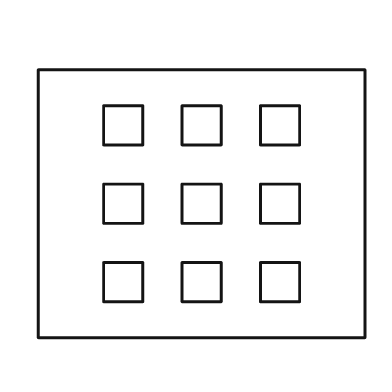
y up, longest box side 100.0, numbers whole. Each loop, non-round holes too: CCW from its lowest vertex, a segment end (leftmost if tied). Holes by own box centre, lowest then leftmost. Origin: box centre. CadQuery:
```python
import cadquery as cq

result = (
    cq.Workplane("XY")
    .moveTo(-50.0, -41.0)
    .lineTo(50.0, -41.0)
    .lineTo(50.0, 41.0)
    .lineTo(-50.0, 41.0)
    .close()
    .moveTo(-30.0, -30.0)
    .lineTo(-18.0, -30.0)
    .lineTo(-18.0, -18.0)
    .lineTo(-30.0, -18.0)
    .close()
    .moveTo(-6.0, -30.0)
    .lineTo(6.0, -30.0)
    .lineTo(6.0, -18.0)
    .lineTo(-6.0, -18.0)
    .close()
    .moveTo(18.0, -30.0)
    .lineTo(30.0, -30.0)
    .lineTo(30.0, -18.0)
    .lineTo(18.0, -18.0)
    .close()
    .moveTo(-30.0, -6.0)
    .lineTo(-18.0, -6.0)
    .lineTo(-18.0, 6.0)
    .lineTo(-30.0, 6.0)
    .close()
    .moveTo(-6.0, -6.0)
    .lineTo(6.0, -6.0)
    .lineTo(6.0, 6.0)
    .lineTo(-6.0, 6.0)
    .close()
    .moveTo(18.0, -6.0)
    .lineTo(30.0, -6.0)
    .lineTo(30.0, 6.0)
    .lineTo(18.0, 6.0)
    .close()
    .moveTo(-30.0, 18.0)
    .lineTo(-18.0, 18.0)
    .lineTo(-18.0, 30.0)
    .lineTo(-30.0, 30.0)
    .close()
    .moveTo(-6.0, 18.0)
    .lineTo(6.0, 18.0)
    .lineTo(6.0, 30.0)
    .lineTo(-6.0, 30.0)
    .close()
    .moveTo(18.0, 18.0)
    .lineTo(30.0, 18.0)
    .lineTo(30.0, 30.0)
    .lineTo(18.0, 30.0)
    .close()
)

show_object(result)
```